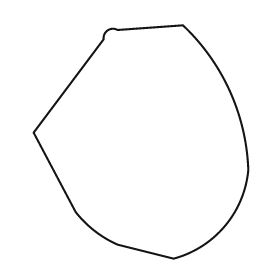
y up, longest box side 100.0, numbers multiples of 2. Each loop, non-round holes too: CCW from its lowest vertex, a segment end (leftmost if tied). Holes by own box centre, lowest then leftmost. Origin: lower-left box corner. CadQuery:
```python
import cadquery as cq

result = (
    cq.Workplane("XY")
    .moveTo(60.0, 0.0)
    .threePointArc((82.0, 14.0), (92.0, 38.0))
    .threePointArc((84.0, 72.0), (64.0, 100.0))
    .lineTo(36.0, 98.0)
    .threePointArc((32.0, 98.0), (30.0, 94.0))
    .lineTo(0.0, 54.0)
    .lineTo(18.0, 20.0)
    .threePointArc((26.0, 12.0), (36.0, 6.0))
    .close()
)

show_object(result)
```